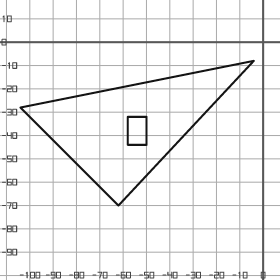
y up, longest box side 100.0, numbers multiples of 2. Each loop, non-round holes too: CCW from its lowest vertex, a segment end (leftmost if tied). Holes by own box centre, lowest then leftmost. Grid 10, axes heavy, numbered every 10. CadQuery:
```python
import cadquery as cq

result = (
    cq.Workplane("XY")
    .moveTo(-62.0, -70.0)
    .lineTo(-4.0, -8.0)
    .lineTo(-104.0, -28.0)
    .close()
    .moveTo(-58.0, -44.0)
    .lineTo(-50.0, -44.0)
    .lineTo(-50.0, -32.0)
    .lineTo(-58.0, -32.0)
    .close()
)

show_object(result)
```